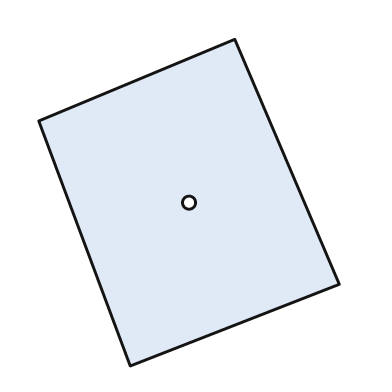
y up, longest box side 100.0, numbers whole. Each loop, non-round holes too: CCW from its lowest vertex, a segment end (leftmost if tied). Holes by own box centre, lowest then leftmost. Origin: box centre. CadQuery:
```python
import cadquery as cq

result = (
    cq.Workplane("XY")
    .moveTo(-18.0, -50.0)
    .lineTo(46.0, -25.0)
    .lineTo(14.0, 50.0)
    .lineTo(-46.0, 25.0)
    .close()
    .moveTo(0.0, 0.0)
    .circle(2.0)
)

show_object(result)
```